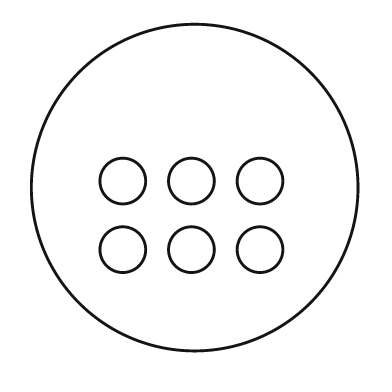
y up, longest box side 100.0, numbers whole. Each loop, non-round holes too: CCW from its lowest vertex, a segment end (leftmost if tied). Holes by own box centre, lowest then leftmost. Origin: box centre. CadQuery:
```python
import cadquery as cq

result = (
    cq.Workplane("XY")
    .moveTo(0.0, 0.0)
    .circle(50.0)
    .moveTo(-22.0, -19.0)
    .circle(7.0)
    .moveTo(-1.0, -19.0)
    .circle(7.0)
    .moveTo(20.0, -19.0)
    .circle(7.0)
    .moveTo(-22.0, 2.0)
    .circle(7.0)
    .moveTo(-1.0, 2.0)
    .circle(7.0)
    .moveTo(20.0, 2.0)
    .circle(7.0)
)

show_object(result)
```